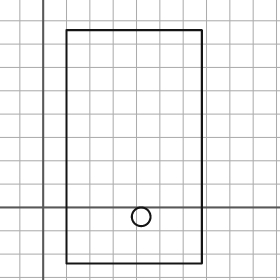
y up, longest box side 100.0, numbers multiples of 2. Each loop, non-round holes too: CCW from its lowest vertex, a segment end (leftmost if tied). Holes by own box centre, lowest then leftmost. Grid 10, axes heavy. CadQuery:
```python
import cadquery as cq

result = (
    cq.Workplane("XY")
    .moveTo(10.0, -24.0)
    .lineTo(68.0, -24.0)
    .lineTo(68.0, 76.0)
    .lineTo(10.0, 76.0)
    .close()
    .moveTo(42.0, -4.0)
    .circle(4.0)
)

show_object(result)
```